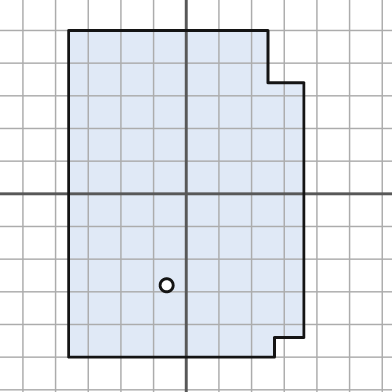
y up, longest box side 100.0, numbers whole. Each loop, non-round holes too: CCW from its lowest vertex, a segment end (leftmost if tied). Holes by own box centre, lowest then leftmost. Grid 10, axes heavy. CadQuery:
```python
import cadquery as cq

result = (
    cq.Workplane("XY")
    .moveTo(-36.0, -50.0)
    .lineTo(27.0, -50.0)
    .lineTo(27.0, -44.0)
    .lineTo(36.0, -44.0)
    .lineTo(36.0, 34.0)
    .lineTo(25.0, 34.0)
    .lineTo(25.0, 50.0)
    .lineTo(-36.0, 50.0)
    .close()
    .moveTo(-6.0, -28.0)
    .circle(2.0)
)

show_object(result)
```